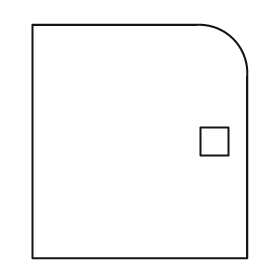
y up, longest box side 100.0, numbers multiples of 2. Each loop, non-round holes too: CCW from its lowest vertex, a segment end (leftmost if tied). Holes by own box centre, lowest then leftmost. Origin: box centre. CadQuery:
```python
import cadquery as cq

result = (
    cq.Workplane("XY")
    .moveTo(-46.0, -50.0)
    .lineTo(46.0, -50.0)
    .lineTo(46.0, 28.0)
    .threePointArc((40.0, 44.0), (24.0, 50.0))
    .lineTo(-46.0, 50.0)
    .close()
    .moveTo(26.0, -6.0)
    .lineTo(38.0, -6.0)
    .lineTo(38.0, 6.0)
    .lineTo(26.0, 6.0)
    .close()
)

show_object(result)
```